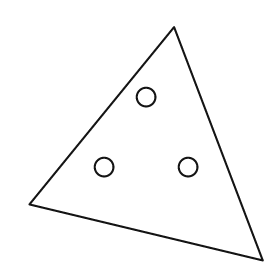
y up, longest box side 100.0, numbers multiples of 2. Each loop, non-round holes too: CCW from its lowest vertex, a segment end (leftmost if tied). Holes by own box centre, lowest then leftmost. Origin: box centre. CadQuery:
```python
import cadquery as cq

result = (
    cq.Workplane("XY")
    .moveTo(50.0, -50.0)
    .lineTo(12.0, 50.0)
    .lineTo(-50.0, -26.0)
    .close()
    .moveTo(-18.0, -10.0)
    .circle(4.0)
    .moveTo(18.0, -10.0)
    .circle(4.0)
    .moveTo(0.0, 20.0)
    .circle(4.0)
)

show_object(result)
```